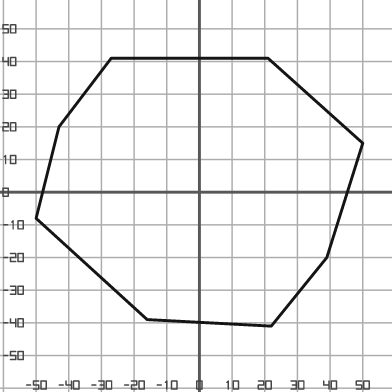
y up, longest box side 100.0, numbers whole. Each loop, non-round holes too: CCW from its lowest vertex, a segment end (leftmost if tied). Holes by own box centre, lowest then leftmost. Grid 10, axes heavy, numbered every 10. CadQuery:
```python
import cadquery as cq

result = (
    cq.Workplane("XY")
    .moveTo(22.0, -41.0)
    .lineTo(39.0, -20.0)
    .lineTo(50.0, 15.0)
    .lineTo(21.0, 41.0)
    .lineTo(-27.0, 41.0)
    .lineTo(-43.0, 20.0)
    .lineTo(-50.0, -8.0)
    .lineTo(-16.0, -39.0)
    .close()
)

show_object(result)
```